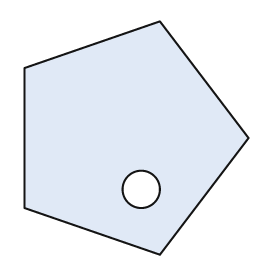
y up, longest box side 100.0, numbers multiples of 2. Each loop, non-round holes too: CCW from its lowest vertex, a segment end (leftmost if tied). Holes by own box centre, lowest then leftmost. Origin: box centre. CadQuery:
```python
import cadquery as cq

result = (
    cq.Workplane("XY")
    .moveTo(10.0, -50.0)
    .lineTo(48.0, 0.0)
    .lineTo(10.0, 50.0)
    .lineTo(-48.0, 30.0)
    .lineTo(-48.0, -30.0)
    .close()
    .moveTo(2.0, -22.0)
    .circle(8.0)
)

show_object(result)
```